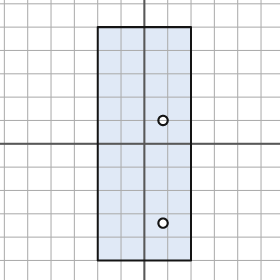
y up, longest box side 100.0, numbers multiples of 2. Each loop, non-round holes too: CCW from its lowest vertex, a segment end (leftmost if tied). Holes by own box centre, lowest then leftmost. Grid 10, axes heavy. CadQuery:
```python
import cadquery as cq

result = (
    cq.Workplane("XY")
    .moveTo(-20.0, -50.0)
    .lineTo(20.0, -50.0)
    .lineTo(20.0, 50.0)
    .lineTo(-20.0, 50.0)
    .close()
    .moveTo(8.0, -34.0)
    .circle(2.0)
    .moveTo(8.0, 10.0)
    .circle(2.0)
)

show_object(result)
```